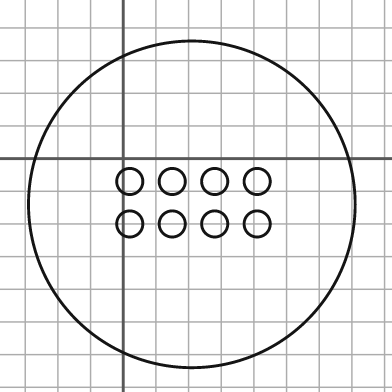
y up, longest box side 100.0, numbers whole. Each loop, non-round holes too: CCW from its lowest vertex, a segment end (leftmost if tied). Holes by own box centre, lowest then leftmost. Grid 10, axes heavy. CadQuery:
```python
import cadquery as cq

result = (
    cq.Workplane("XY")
    .moveTo(21.0, -14.0)
    .circle(50.0)
    .moveTo(2.0, -20.0)
    .circle(4.0)
    .moveTo(15.0, -20.0)
    .circle(4.0)
    .moveTo(28.0, -20.0)
    .circle(4.0)
    .moveTo(41.0, -20.0)
    .circle(4.0)
    .moveTo(2.0, -7.0)
    .circle(4.0)
    .moveTo(15.0, -7.0)
    .circle(4.0)
    .moveTo(28.0, -7.0)
    .circle(4.0)
    .moveTo(41.0, -7.0)
    .circle(4.0)
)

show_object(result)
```